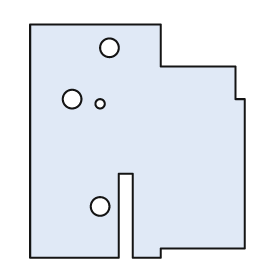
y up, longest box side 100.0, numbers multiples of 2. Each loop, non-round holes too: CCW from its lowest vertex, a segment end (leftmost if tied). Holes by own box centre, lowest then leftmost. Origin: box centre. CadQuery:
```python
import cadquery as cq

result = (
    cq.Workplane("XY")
    .moveTo(-46.0, -50.0)
    .lineTo(-8.0, -50.0)
    .lineTo(-8.0, -14.0)
    .lineTo(-2.0, -14.0)
    .lineTo(-2.0, -50.0)
    .lineTo(10.0, -50.0)
    .lineTo(10.0, -46.0)
    .lineTo(46.0, -46.0)
    .lineTo(46.0, 18.0)
    .lineTo(42.0, 18.0)
    .lineTo(42.0, 32.0)
    .lineTo(10.0, 32.0)
    .lineTo(10.0, 50.0)
    .lineTo(-46.0, 50.0)
    .close()
    .moveTo(-16.0, -28.0)
    .circle(4.0)
    .moveTo(-16.0, 16.0)
    .circle(2.0)
    .moveTo(-28.0, 18.0)
    .circle(4.0)
    .moveTo(-12.0, 40.0)
    .circle(4.0)
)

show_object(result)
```